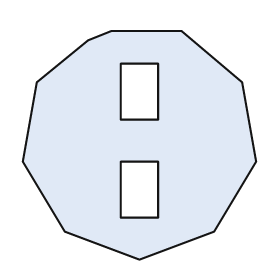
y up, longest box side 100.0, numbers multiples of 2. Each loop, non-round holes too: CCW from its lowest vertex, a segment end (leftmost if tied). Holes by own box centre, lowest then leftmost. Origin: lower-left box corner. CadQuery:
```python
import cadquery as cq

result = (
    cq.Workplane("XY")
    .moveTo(50.0, 0.0)
    .lineTo(82.0, 12.0)
    .lineTo(100.0, 42.0)
    .lineTo(94.0, 76.0)
    .lineTo(68.0, 98.0)
    .lineTo(38.0, 98.0)
    .lineTo(28.0, 94.0)
    .lineTo(6.0, 76.0)
    .lineTo(0.0, 42.0)
    .lineTo(18.0, 12.0)
    .close()
    .moveTo(42.0, 18.0)
    .lineTo(58.0, 18.0)
    .lineTo(58.0, 42.0)
    .lineTo(42.0, 42.0)
    .close()
    .moveTo(42.0, 60.0)
    .lineTo(58.0, 60.0)
    .lineTo(58.0, 84.0)
    .lineTo(42.0, 84.0)
    .close()
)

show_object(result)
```